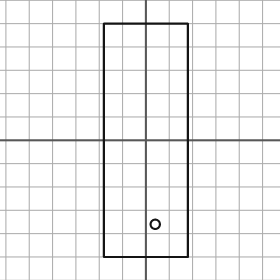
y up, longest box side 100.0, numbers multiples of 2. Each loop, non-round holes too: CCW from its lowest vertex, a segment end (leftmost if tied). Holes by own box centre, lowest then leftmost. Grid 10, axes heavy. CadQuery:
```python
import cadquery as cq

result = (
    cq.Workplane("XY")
    .moveTo(-18.0, -50.0)
    .lineTo(18.0, -50.0)
    .lineTo(18.0, 50.0)
    .lineTo(-18.0, 50.0)
    .close()
    .moveTo(4.0, -36.0)
    .circle(2.0)
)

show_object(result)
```